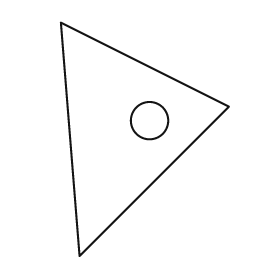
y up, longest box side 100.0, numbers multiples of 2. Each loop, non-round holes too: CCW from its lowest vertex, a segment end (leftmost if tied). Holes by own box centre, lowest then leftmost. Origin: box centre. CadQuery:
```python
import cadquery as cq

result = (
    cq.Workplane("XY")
    .moveTo(-28.0, -50.0)
    .lineTo(36.0, 14.0)
    .lineTo(-36.0, 50.0)
    .close()
    .moveTo(2.0, 8.0)
    .circle(8.0)
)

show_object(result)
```